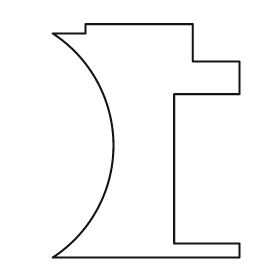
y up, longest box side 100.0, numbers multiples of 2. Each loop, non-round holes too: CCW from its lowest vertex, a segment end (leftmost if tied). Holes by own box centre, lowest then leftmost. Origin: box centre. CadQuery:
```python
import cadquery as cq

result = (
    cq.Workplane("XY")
    .moveTo(-40.0, -50.0)
    .lineTo(40.0, -50.0)
    .lineTo(40.0, -44.0)
    .lineTo(12.0, -44.0)
    .lineTo(12.0, 20.0)
    .lineTo(40.0, 20.0)
    .lineTo(40.0, 34.0)
    .lineTo(20.0, 34.0)
    .lineTo(20.0, 50.0)
    .lineTo(-26.0, 50.0)
    .lineTo(-26.0, 46.0)
    .lineTo(-40.0, 46.0)
    .threePointArc((-14.0, -2.0), (-40.0, -50.0))
    .close()
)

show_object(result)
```